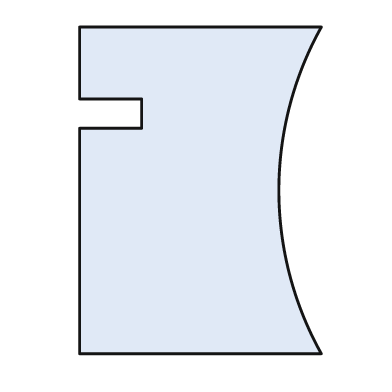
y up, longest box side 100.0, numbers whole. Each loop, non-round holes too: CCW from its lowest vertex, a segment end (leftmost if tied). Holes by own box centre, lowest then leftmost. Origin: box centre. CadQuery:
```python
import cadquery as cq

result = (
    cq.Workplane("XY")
    .moveTo(-37.0, -50.0)
    .lineTo(37.0, -50.0)
    .threePointArc((24.0, 0.0), (37.0, 50.0))
    .lineTo(-37.0, 50.0)
    .lineTo(-37.0, 28.0)
    .lineTo(-18.0, 28.0)
    .lineTo(-18.0, 19.0)
    .lineTo(-37.0, 19.0)
    .close()
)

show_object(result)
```